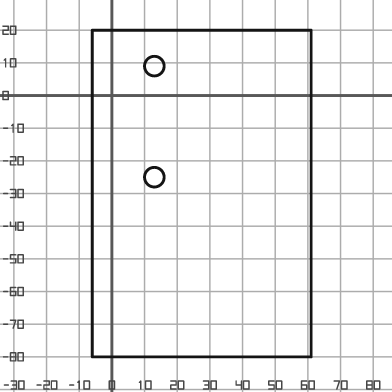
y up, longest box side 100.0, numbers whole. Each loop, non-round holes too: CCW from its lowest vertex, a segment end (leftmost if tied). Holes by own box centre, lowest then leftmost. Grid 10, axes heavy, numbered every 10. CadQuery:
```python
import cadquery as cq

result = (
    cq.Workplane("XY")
    .moveTo(-6.0, -80.0)
    .lineTo(61.0, -80.0)
    .lineTo(61.0, 20.0)
    .lineTo(-6.0, 20.0)
    .close()
    .moveTo(13.0, -25.0)
    .circle(3.0)
    .moveTo(13.0, 9.0)
    .circle(3.0)
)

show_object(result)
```